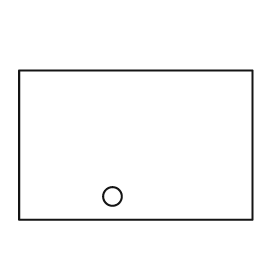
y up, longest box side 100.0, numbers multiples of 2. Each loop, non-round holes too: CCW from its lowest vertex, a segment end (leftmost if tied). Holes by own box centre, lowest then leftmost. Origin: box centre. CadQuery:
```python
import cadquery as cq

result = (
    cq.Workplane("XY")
    .moveTo(-50.0, -32.0)
    .lineTo(50.0, -32.0)
    .lineTo(50.0, 32.0)
    .lineTo(-50.0, 32.0)
    .close()
    .moveTo(-10.0, -22.0)
    .circle(4.0)
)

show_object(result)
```